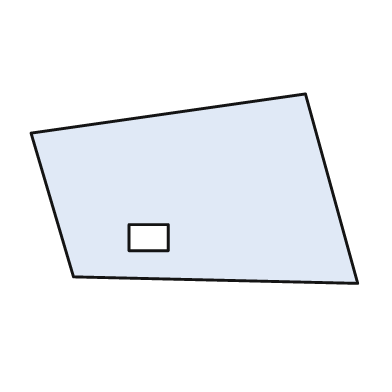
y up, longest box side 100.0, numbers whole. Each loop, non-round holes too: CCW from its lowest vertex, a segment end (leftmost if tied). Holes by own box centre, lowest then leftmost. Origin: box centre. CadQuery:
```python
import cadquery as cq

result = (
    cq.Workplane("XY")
    .moveTo(50.0, -29.0)
    .lineTo(34.0, 29.0)
    .lineTo(-50.0, 17.0)
    .lineTo(-37.0, -27.0)
    .close()
    .moveTo(-20.0, -19.0)
    .lineTo(-8.0, -19.0)
    .lineTo(-8.0, -11.0)
    .lineTo(-20.0, -11.0)
    .close()
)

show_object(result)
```